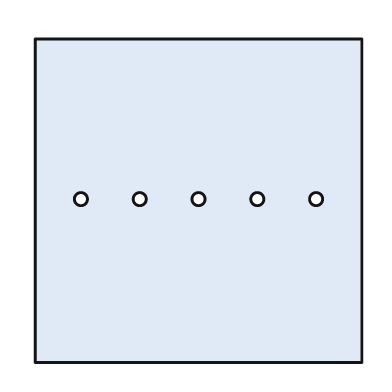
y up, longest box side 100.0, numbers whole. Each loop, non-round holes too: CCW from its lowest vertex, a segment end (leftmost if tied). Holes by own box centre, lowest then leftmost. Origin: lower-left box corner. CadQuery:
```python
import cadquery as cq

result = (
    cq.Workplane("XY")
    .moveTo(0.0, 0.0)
    .lineTo(100.0, 0.0)
    .lineTo(100.0, 99.0)
    .lineTo(0.0, 99.0)
    .close()
    .moveTo(14.0, 50.0)
    .circle(2.0)
    .moveTo(32.0, 50.0)
    .circle(2.0)
    .moveTo(50.0, 50.0)
    .circle(2.0)
    .moveTo(68.0, 50.0)
    .circle(2.0)
    .moveTo(86.0, 50.0)
    .circle(2.0)
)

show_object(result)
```